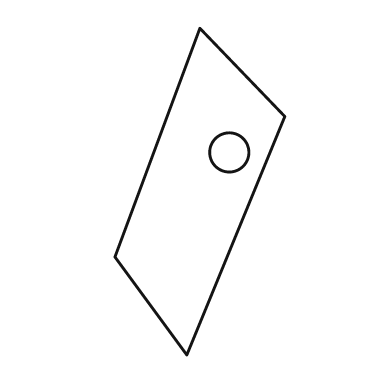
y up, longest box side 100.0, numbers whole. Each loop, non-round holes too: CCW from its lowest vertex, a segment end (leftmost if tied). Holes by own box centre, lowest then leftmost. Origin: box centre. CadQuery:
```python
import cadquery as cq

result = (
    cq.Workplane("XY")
    .moveTo(-4.0, -50.0)
    .lineTo(26.0, 23.0)
    .lineTo(0.0, 50.0)
    .lineTo(-26.0, -20.0)
    .close()
    .moveTo(9.0, 12.0)
    .circle(6.0)
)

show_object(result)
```